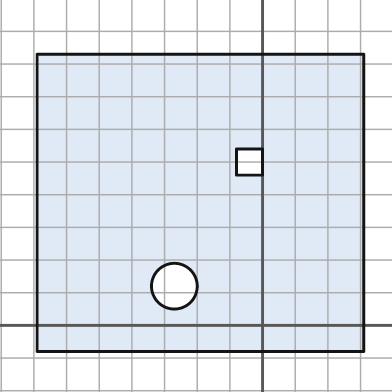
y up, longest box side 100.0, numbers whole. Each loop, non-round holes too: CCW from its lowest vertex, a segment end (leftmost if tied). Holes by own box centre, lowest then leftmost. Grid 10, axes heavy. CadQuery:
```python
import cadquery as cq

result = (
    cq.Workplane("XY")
    .moveTo(-69.0, -8.0)
    .lineTo(31.0, -8.0)
    .lineTo(31.0, 83.0)
    .lineTo(-69.0, 83.0)
    .close()
    .moveTo(-27.0, 12.0)
    .circle(7.0)
    .moveTo(-8.0, 46.0)
    .lineTo(0.0, 46.0)
    .lineTo(0.0, 54.0)
    .lineTo(-8.0, 54.0)
    .close()
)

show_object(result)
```